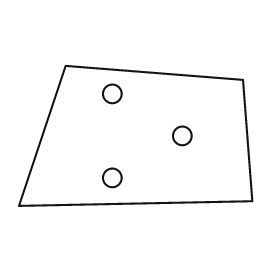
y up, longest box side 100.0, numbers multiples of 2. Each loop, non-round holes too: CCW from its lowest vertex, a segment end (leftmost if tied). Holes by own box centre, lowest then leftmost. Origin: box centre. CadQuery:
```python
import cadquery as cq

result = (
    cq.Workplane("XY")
    .moveTo(-50.0, -30.0)
    .lineTo(50.0, -28.0)
    .lineTo(46.0, 24.0)
    .lineTo(-30.0, 30.0)
    .close()
    .moveTo(-10.0, -18.0)
    .circle(4.0)
    .moveTo(20.0, 0.0)
    .circle(4.0)
    .moveTo(-10.0, 18.0)
    .circle(4.0)
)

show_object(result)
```